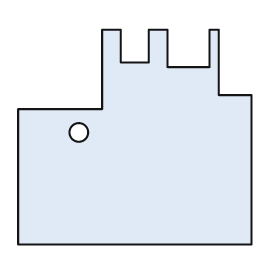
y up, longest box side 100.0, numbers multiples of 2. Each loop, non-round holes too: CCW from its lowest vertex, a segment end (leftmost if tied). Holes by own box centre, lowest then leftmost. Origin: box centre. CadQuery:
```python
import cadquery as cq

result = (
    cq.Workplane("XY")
    .moveTo(-50.0, -46.0)
    .lineTo(50.0, -46.0)
    .lineTo(50.0, 18.0)
    .lineTo(36.0, 18.0)
    .lineTo(36.0, 46.0)
    .lineTo(32.0, 46.0)
    .lineTo(32.0, 30.0)
    .lineTo(14.0, 30.0)
    .lineTo(14.0, 46.0)
    .lineTo(6.0, 46.0)
    .lineTo(6.0, 32.0)
    .lineTo(-6.0, 32.0)
    .lineTo(-6.0, 46.0)
    .lineTo(-14.0, 46.0)
    .lineTo(-14.0, 12.0)
    .lineTo(-50.0, 12.0)
    .close()
    .moveTo(-24.0, 2.0)
    .circle(4.0)
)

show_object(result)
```